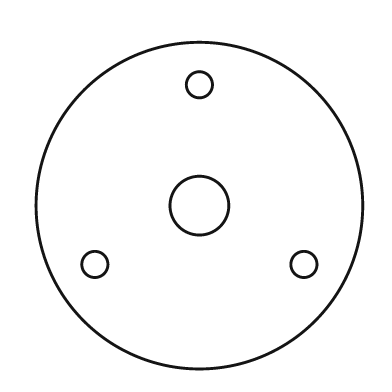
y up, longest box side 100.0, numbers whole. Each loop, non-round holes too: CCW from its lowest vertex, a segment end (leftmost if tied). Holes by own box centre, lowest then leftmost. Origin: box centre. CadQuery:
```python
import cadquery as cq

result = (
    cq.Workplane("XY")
    .moveTo(0.0, 0.0)
    .circle(50.0)
    .moveTo(-32.0, -18.0)
    .circle(4.0)
    .moveTo(32.0, -18.0)
    .circle(4.0)
    .moveTo(0.0, 0.0)
    .circle(9.0)
    .moveTo(0.0, 37.0)
    .circle(4.0)
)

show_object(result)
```